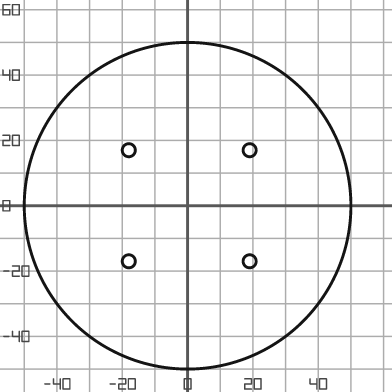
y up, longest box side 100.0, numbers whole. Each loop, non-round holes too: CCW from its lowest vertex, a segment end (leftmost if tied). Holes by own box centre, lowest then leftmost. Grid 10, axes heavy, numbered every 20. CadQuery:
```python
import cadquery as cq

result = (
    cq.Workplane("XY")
    .moveTo(0.0, 0.0)
    .circle(50.0)
    .moveTo(-18.0, -17.0)
    .circle(2.0)
    .moveTo(19.0, -17.0)
    .circle(2.0)
    .moveTo(-18.0, 17.0)
    .circle(2.0)
    .moveTo(19.0, 17.0)
    .circle(2.0)
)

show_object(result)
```